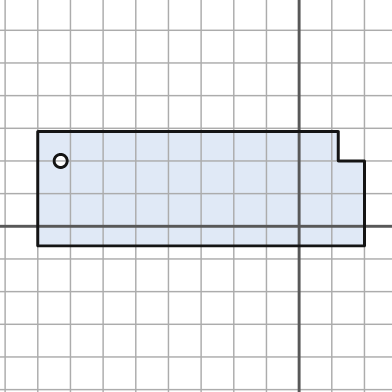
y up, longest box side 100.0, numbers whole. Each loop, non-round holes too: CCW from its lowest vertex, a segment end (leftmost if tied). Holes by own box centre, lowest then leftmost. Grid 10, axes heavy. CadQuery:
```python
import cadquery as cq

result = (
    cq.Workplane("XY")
    .moveTo(-80.0, -6.0)
    .lineTo(20.0, -6.0)
    .lineTo(20.0, 20.0)
    .lineTo(12.0, 20.0)
    .lineTo(12.0, 29.0)
    .lineTo(-80.0, 29.0)
    .close()
    .moveTo(-73.0, 20.0)
    .circle(2.0)
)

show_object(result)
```